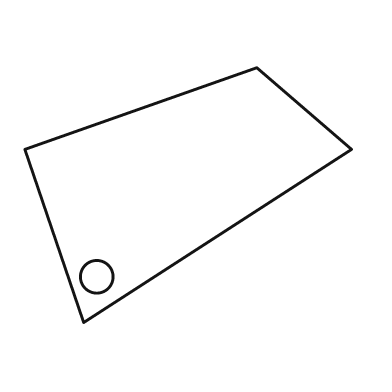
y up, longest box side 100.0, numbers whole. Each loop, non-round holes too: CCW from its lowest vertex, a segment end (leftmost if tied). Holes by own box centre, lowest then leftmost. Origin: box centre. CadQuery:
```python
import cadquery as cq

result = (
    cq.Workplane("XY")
    .moveTo(-32.0, -39.0)
    .lineTo(50.0, 14.0)
    .lineTo(21.0, 39.0)
    .lineTo(-50.0, 14.0)
    .close()
    .moveTo(-28.0, -25.0)
    .circle(5.0)
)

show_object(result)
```